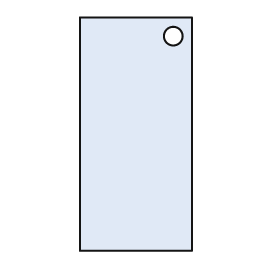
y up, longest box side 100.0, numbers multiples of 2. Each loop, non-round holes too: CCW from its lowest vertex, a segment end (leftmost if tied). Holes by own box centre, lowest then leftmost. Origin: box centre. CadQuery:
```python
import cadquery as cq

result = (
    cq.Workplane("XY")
    .moveTo(-24.0, -50.0)
    .lineTo(24.0, -50.0)
    .lineTo(24.0, 50.0)
    .lineTo(-24.0, 50.0)
    .close()
    .moveTo(16.0, 42.0)
    .circle(4.0)
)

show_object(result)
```